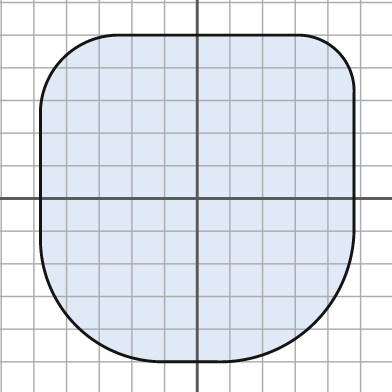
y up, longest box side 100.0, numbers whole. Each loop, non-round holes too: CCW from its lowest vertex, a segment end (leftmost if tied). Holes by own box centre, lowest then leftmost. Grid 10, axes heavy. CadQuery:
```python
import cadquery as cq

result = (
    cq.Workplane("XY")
    .moveTo(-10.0, -50.0)
    .lineTo(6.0, -50.0)
    .threePointArc((36.0, -38.0), (48.0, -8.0))
    .lineTo(48.0, 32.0)
    .threePointArc((43.0, 45.0), (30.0, 50.0))
    .lineTo(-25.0, 50.0)
    .threePointArc((-41.0, 43.0), (-48.0, 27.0))
    .lineTo(-48.0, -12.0)
    .threePointArc((-37.0, -39.0), (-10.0, -50.0))
    .close()
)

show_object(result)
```